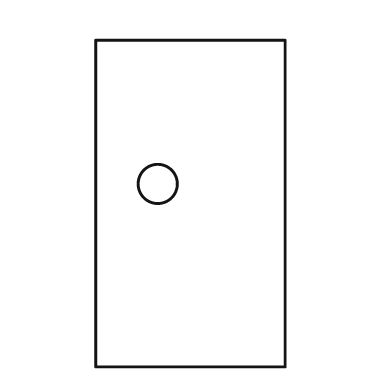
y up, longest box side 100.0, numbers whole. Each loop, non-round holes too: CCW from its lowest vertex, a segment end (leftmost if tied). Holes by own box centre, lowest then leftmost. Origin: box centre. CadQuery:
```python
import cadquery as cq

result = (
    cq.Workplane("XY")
    .moveTo(-29.0, -50.0)
    .lineTo(29.0, -50.0)
    .lineTo(29.0, 50.0)
    .lineTo(-29.0, 50.0)
    .close()
    .moveTo(-10.0, 6.0)
    .circle(6.0)
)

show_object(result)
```